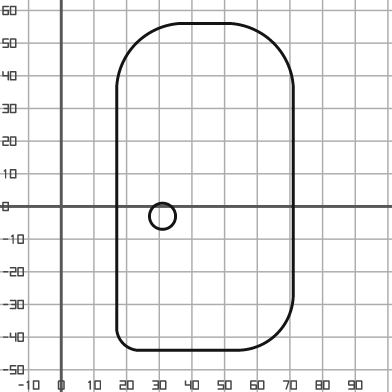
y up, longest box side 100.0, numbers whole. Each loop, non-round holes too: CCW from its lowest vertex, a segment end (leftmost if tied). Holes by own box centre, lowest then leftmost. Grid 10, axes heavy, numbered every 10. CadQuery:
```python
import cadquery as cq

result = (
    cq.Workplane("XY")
    .moveTo(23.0, -44.0)
    .lineTo(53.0, -44.0)
    .threePointArc((66.0, -39.0), (71.0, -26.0))
    .lineTo(71.0, 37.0)
    .threePointArc((65.0, 50.0), (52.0, 56.0))
    .lineTo(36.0, 56.0)
    .threePointArc((23.0, 50.0), (17.0, 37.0))
    .lineTo(17.0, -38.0)
    .threePointArc((19.0, -42.0), (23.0, -44.0))
    .close()
    .moveTo(31.0, -3.0)
    .circle(4.0)
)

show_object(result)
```